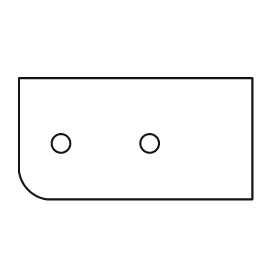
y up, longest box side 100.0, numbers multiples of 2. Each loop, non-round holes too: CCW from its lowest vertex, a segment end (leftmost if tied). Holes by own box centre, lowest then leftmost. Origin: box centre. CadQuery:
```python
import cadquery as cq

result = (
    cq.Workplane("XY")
    .moveTo(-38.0, -26.0)
    .lineTo(50.0, -26.0)
    .lineTo(50.0, 26.0)
    .lineTo(-50.0, 26.0)
    .lineTo(-50.0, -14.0)
    .threePointArc((-46.0, -22.0), (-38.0, -26.0))
    .close()
    .moveTo(-32.0, -2.0)
    .circle(4.0)
    .moveTo(6.0, -2.0)
    .circle(4.0)
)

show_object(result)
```